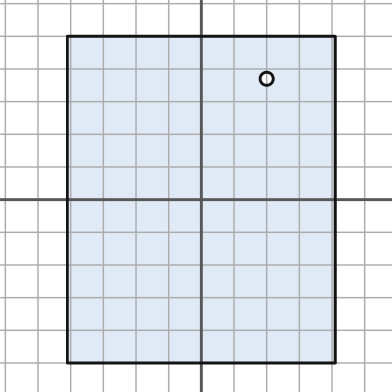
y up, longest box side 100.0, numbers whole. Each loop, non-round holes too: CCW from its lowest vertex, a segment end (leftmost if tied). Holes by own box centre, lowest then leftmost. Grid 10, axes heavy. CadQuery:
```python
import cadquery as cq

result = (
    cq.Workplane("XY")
    .moveTo(-41.0, -50.0)
    .lineTo(41.0, -50.0)
    .lineTo(41.0, 50.0)
    .lineTo(-41.0, 50.0)
    .close()
    .moveTo(20.0, 37.0)
    .circle(2.0)
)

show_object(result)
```